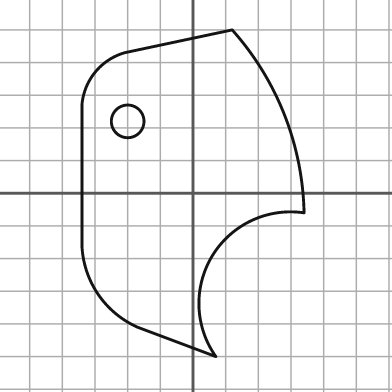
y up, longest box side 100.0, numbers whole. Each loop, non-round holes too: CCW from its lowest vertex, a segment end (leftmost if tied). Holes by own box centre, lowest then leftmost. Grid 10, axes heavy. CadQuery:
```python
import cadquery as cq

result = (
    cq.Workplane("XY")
    .moveTo(7.0, -50.0)
    .threePointArc((6.0, -19.0), (34.0, -6.0))
    .threePointArc((28.0, 24.0), (12.0, 50.0))
    .lineTo(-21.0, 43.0)
    .threePointArc((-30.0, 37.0), (-34.0, 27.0))
    .lineTo(-34.0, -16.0)
    .threePointArc((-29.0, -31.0), (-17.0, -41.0))
    .close()
    .moveTo(-20.0, 22.0)
    .circle(5.0)
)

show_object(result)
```